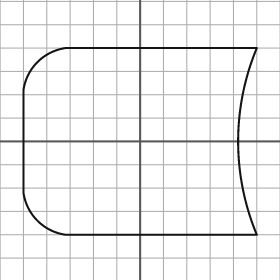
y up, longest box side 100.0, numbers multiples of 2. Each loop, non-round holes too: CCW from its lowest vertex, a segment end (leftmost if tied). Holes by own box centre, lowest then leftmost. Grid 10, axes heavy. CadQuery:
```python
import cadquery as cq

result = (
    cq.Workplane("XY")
    .moveTo(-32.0, -40.0)
    .lineTo(50.0, -40.0)
    .threePointArc((42.0, 0.0), (50.0, 40.0))
    .lineTo(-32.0, 40.0)
    .threePointArc((-44.0, 34.0), (-50.0, 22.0))
    .lineTo(-50.0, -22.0)
    .threePointArc((-44.0, -34.0), (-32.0, -40.0))
    .close()
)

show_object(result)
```